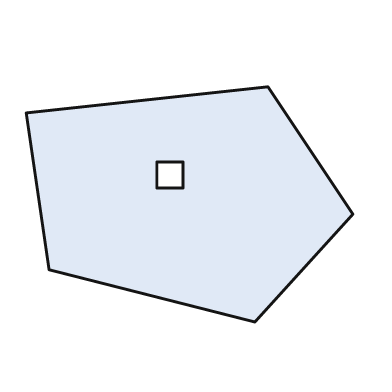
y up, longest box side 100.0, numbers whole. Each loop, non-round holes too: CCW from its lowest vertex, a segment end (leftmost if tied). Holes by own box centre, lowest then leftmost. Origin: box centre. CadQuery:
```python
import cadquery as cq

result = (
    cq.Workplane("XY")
    .moveTo(20.0, -36.0)
    .lineTo(50.0, -3.0)
    .lineTo(24.0, 36.0)
    .lineTo(-50.0, 28.0)
    .lineTo(-43.0, -20.0)
    .close()
    .moveTo(-10.0, 5.0)
    .lineTo(-2.0, 5.0)
    .lineTo(-2.0, 13.0)
    .lineTo(-10.0, 13.0)
    .close()
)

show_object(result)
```